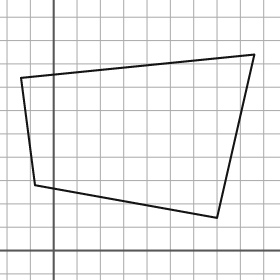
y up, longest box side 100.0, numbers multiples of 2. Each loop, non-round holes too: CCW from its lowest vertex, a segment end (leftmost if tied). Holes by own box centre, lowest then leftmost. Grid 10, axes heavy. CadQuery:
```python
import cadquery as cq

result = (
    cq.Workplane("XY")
    .moveTo(70.0, 14.0)
    .lineTo(86.0, 84.0)
    .lineTo(-14.0, 74.0)
    .lineTo(-8.0, 28.0)
    .close()
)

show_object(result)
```